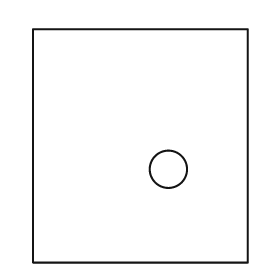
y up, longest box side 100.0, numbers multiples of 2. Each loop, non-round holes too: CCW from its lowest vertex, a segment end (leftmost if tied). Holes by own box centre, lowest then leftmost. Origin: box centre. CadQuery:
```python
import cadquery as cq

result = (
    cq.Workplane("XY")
    .moveTo(-46.0, -50.0)
    .lineTo(46.0, -50.0)
    .lineTo(46.0, 50.0)
    .lineTo(-46.0, 50.0)
    .close()
    .moveTo(12.0, -10.0)
    .circle(8.0)
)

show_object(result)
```